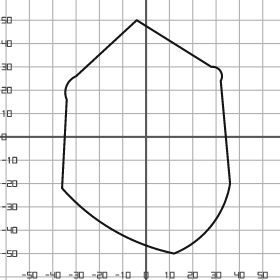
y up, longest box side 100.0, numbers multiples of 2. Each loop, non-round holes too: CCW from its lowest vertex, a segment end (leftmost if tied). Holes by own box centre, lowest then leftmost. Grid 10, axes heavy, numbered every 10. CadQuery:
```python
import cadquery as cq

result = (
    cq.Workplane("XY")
    .moveTo(12.0, -50.0)
    .threePointArc((28.0, -38.0), (36.0, -20.0))
    .lineTo(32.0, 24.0)
    .threePointArc((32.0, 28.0), (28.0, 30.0))
    .lineTo(-4.0, 50.0)
    .lineTo(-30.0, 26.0)
    .threePointArc((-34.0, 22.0), (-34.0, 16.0))
    .lineTo(-36.0, -22.0)
    .threePointArc((-14.0, -40.0), (12.0, -50.0))
    .close()
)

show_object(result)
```